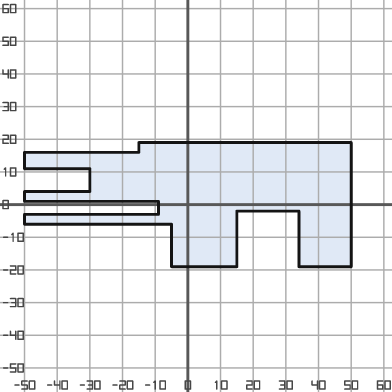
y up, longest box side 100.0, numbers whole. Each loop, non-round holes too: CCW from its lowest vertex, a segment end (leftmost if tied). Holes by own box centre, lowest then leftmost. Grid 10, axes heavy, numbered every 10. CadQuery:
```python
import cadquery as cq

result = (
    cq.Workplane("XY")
    .moveTo(-5.0, -19.0)
    .lineTo(15.0, -19.0)
    .lineTo(15.0, -2.0)
    .lineTo(34.0, -2.0)
    .lineTo(34.0, -19.0)
    .lineTo(50.0, -19.0)
    .lineTo(50.0, 19.0)
    .lineTo(-15.0, 19.0)
    .lineTo(-15.0, 16.0)
    .lineTo(-50.0, 16.0)
    .lineTo(-50.0, 11.0)
    .lineTo(-30.0, 11.0)
    .lineTo(-30.0, 4.0)
    .lineTo(-50.0, 4.0)
    .lineTo(-50.0, 1.0)
    .lineTo(-9.0, 1.0)
    .lineTo(-9.0, -3.0)
    .lineTo(-50.0, -3.0)
    .lineTo(-50.0, -6.0)
    .lineTo(-5.0, -6.0)
    .close()
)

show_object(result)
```